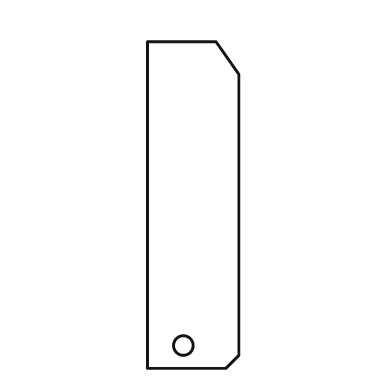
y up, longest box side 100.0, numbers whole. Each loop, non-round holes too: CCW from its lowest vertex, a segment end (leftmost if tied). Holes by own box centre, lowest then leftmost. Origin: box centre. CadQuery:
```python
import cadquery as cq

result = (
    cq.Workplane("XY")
    .moveTo(-14.0, -50.0)
    .lineTo(10.0, -50.0)
    .lineTo(14.0, -46.0)
    .lineTo(14.0, 40.0)
    .lineTo(7.0, 50.0)
    .lineTo(-14.0, 50.0)
    .close()
    .moveTo(-3.0, -43.0)
    .circle(3.0)
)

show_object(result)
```